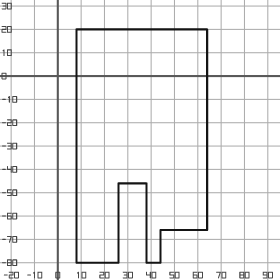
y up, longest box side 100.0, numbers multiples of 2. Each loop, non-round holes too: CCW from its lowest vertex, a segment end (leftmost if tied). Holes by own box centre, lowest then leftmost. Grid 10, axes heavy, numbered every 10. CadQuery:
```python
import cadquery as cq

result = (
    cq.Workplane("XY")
    .moveTo(8.0, -80.0)
    .lineTo(26.0, -80.0)
    .lineTo(26.0, -46.0)
    .lineTo(38.0, -46.0)
    .lineTo(38.0, -80.0)
    .lineTo(44.0, -80.0)
    .lineTo(44.0, -66.0)
    .lineTo(64.0, -66.0)
    .lineTo(64.0, 20.0)
    .lineTo(8.0, 20.0)
    .close()
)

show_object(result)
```